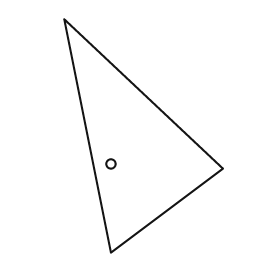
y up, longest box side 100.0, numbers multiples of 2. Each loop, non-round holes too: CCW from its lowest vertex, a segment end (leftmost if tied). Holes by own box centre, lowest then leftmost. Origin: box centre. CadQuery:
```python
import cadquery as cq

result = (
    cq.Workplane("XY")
    .moveTo(-14.0, -50.0)
    .lineTo(34.0, -14.0)
    .lineTo(-34.0, 50.0)
    .close()
    .moveTo(-14.0, -12.0)
    .circle(2.0)
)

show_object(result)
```